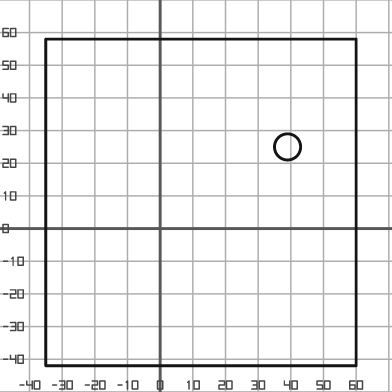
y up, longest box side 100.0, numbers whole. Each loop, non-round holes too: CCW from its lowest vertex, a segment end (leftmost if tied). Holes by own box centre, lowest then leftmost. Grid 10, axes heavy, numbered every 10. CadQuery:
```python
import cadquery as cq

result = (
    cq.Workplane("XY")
    .moveTo(-35.0, -42.0)
    .lineTo(60.0, -42.0)
    .lineTo(60.0, 58.0)
    .lineTo(-35.0, 58.0)
    .close()
    .moveTo(39.0, 25.0)
    .circle(4.0)
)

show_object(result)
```